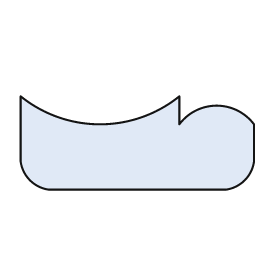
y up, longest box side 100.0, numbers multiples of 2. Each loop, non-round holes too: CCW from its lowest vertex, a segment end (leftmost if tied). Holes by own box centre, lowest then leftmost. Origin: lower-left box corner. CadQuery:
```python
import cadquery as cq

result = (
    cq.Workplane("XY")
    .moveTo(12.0, 0.0)
    .lineTo(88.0, 0.0)
    .threePointArc((96.0, 4.0), (100.0, 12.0))
    .lineTo(100.0, 28.0)
    .threePointArc((84.0, 36.0), (68.0, 28.0))
    .lineTo(68.0, 40.0)
    .threePointArc((34.0, 28.0), (0.0, 40.0))
    .lineTo(0.0, 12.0)
    .threePointArc((4.0, 4.0), (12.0, 0.0))
    .close()
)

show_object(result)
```